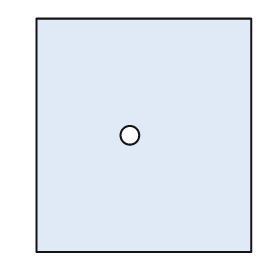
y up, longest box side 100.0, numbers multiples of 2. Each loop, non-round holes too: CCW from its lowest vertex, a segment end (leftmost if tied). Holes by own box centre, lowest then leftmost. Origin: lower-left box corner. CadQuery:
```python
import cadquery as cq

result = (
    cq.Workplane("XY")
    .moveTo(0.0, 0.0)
    .lineTo(92.0, 0.0)
    .lineTo(92.0, 100.0)
    .lineTo(0.0, 100.0)
    .close()
    .moveTo(40.0, 50.0)
    .circle(4.0)
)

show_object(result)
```